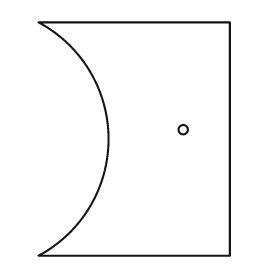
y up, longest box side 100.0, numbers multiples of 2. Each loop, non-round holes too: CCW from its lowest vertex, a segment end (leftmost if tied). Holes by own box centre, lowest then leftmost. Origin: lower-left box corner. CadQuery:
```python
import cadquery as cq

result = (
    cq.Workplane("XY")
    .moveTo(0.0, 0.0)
    .lineTo(82.0, 0.0)
    .lineTo(82.0, 100.0)
    .lineTo(0.0, 100.0)
    .threePointArc((30.0, 50.0), (0.0, 0.0))
    .close()
    .moveTo(62.0, 54.0)
    .circle(2.0)
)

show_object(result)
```